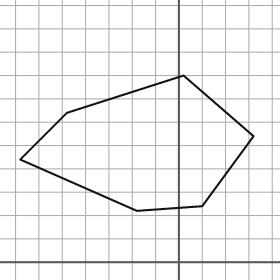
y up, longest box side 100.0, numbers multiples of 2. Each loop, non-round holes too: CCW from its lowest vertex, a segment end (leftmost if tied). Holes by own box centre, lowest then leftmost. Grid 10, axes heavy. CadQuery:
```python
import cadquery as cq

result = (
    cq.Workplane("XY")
    .moveTo(-18.0, 22.0)
    .lineTo(10.0, 24.0)
    .lineTo(32.0, 54.0)
    .lineTo(2.0, 80.0)
    .lineTo(-48.0, 64.0)
    .lineTo(-68.0, 44.0)
    .close()
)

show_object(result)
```